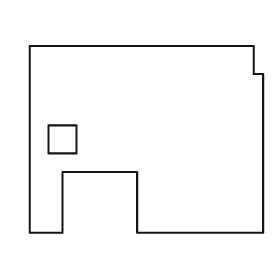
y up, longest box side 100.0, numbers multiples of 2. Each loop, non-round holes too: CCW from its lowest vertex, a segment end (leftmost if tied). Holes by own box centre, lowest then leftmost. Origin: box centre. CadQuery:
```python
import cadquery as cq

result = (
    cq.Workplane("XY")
    .moveTo(-50.0, -40.0)
    .lineTo(-36.0, -40.0)
    .lineTo(-36.0, -14.0)
    .lineTo(-4.0, -14.0)
    .lineTo(-4.0, -40.0)
    .lineTo(50.0, -40.0)
    .lineTo(50.0, 28.0)
    .lineTo(46.0, 28.0)
    .lineTo(46.0, 40.0)
    .lineTo(-50.0, 40.0)
    .close()
    .moveTo(-42.0, -6.0)
    .lineTo(-30.0, -6.0)
    .lineTo(-30.0, 6.0)
    .lineTo(-42.0, 6.0)
    .close()
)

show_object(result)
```